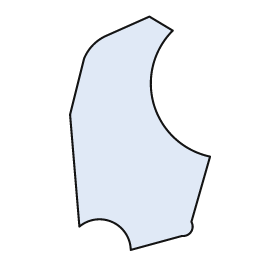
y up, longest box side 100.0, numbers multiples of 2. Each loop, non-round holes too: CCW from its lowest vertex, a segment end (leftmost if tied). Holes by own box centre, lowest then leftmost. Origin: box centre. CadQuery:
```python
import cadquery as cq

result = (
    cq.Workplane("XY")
    .moveTo(-4.0, -50.0)
    .lineTo(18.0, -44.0)
    .threePointArc((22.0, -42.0), (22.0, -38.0))
    .lineTo(30.0, -10.0)
    .threePointArc((6.0, 12.0), (14.0, 44.0))
    .lineTo(4.0, 50.0)
    .lineTo(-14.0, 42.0)
    .threePointArc((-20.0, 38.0), (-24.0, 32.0))
    .lineTo(-30.0, 8.0)
    .lineTo(-26.0, -40.0)
    .threePointArc((-12.0, -38.0), (-4.0, -50.0))
    .close()
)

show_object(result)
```